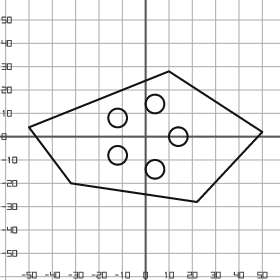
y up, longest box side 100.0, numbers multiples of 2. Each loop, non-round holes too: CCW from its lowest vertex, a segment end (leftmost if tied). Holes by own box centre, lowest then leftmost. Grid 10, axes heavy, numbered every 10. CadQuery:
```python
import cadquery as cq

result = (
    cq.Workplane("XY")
    .moveTo(22.0, -28.0)
    .lineTo(50.0, 2.0)
    .lineTo(10.0, 28.0)
    .lineTo(-50.0, 4.0)
    .lineTo(-32.0, -20.0)
    .close()
    .moveTo(4.0, -14.0)
    .circle(4.0)
    .moveTo(-12.0, -8.0)
    .circle(4.0)
    .moveTo(14.0, 0.0)
    .circle(4.0)
    .moveTo(-12.0, 8.0)
    .circle(4.0)
    .moveTo(4.0, 14.0)
    .circle(4.0)
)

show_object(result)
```